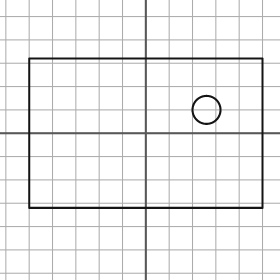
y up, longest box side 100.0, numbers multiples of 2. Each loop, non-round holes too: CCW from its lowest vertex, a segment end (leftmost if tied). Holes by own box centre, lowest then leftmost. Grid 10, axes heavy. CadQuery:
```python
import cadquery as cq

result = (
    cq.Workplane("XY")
    .moveTo(-50.0, -32.0)
    .lineTo(50.0, -32.0)
    .lineTo(50.0, 32.0)
    .lineTo(-50.0, 32.0)
    .close()
    .moveTo(26.0, 10.0)
    .circle(6.0)
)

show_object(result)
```